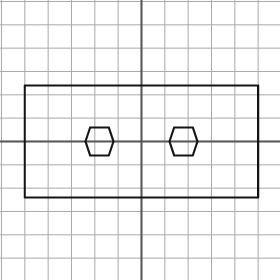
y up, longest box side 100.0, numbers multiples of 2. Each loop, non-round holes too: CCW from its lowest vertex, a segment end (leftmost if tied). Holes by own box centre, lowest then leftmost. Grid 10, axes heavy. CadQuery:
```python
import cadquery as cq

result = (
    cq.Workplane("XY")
    .moveTo(-50.0, -24.0)
    .lineTo(50.0, -24.0)
    .lineTo(50.0, 24.0)
    .lineTo(-50.0, 24.0)
    .close()
    .moveTo(-22.0, -6.0)
    .lineTo(-14.0, -6.0)
    .lineTo(-12.0, 0.0)
    .lineTo(-14.0, 6.0)
    .lineTo(-22.0, 6.0)
    .lineTo(-24.0, 0.0)
    .close()
    .moveTo(14.0, -6.0)
    .lineTo(22.0, -6.0)
    .lineTo(24.0, 0.0)
    .lineTo(22.0, 6.0)
    .lineTo(14.0, 6.0)
    .lineTo(12.0, 0.0)
    .close()
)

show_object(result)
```